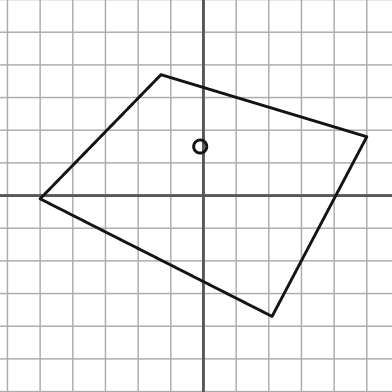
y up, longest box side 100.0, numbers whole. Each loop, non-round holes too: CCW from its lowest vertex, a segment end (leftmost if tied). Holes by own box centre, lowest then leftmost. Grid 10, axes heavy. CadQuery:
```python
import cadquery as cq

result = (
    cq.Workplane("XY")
    .moveTo(21.0, -37.0)
    .lineTo(50.0, 18.0)
    .lineTo(-13.0, 37.0)
    .lineTo(-50.0, -1.0)
    .close()
    .moveTo(-1.0, 15.0)
    .circle(2.0)
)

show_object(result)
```